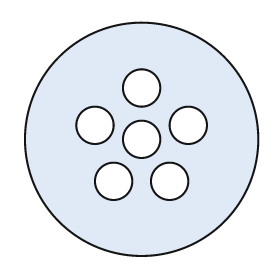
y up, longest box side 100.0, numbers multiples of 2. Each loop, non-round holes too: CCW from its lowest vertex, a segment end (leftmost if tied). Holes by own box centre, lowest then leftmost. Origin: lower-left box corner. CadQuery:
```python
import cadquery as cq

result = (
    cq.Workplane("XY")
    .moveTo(50.0, 50.0)
    .circle(50.0)
    .moveTo(38.0, 32.0)
    .circle(8.0)
    .moveTo(62.0, 32.0)
    .circle(8.0)
    .moveTo(50.0, 50.0)
    .circle(8.0)
    .moveTo(30.0, 56.0)
    .circle(8.0)
    .moveTo(70.0, 56.0)
    .circle(8.0)
    .moveTo(50.0, 72.0)
    .circle(8.0)
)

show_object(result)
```